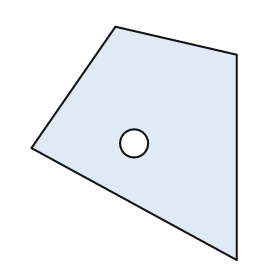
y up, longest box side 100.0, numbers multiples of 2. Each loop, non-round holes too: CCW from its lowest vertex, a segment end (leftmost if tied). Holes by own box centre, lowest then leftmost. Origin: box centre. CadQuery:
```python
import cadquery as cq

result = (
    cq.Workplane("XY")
    .moveTo(44.0, -50.0)
    .lineTo(44.0, 38.0)
    .lineTo(-8.0, 50.0)
    .lineTo(-44.0, -2.0)
    .close()
    .moveTo(0.0, 0.0)
    .circle(6.0)
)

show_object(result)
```